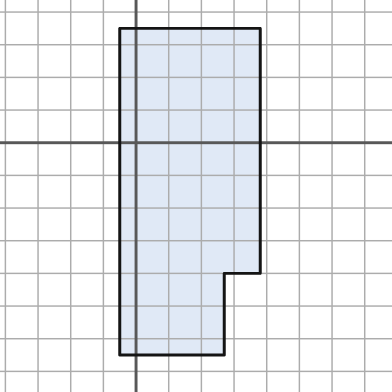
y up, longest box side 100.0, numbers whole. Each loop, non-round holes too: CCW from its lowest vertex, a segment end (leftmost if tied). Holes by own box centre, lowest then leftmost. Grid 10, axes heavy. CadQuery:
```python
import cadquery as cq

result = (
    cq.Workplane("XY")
    .moveTo(-5.0, -65.0)
    .lineTo(27.0, -65.0)
    .lineTo(27.0, -40.0)
    .lineTo(38.0, -40.0)
    .lineTo(38.0, 35.0)
    .lineTo(-5.0, 35.0)
    .close()
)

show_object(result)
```